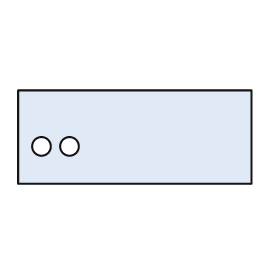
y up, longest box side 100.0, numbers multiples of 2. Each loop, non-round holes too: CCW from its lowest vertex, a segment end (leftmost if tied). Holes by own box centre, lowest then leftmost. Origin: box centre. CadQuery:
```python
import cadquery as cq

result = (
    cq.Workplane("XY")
    .moveTo(-50.0, -20.0)
    .lineTo(50.0, -20.0)
    .lineTo(50.0, 20.0)
    .lineTo(-50.0, 20.0)
    .close()
    .moveTo(-40.0, -4.0)
    .circle(4.0)
    .moveTo(-28.0, -4.0)
    .circle(4.0)
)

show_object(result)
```